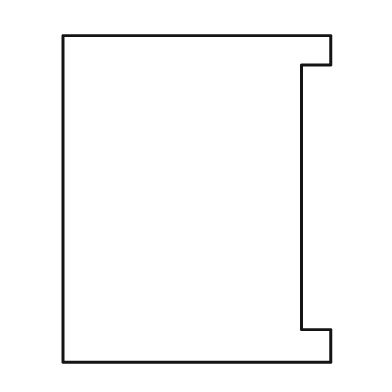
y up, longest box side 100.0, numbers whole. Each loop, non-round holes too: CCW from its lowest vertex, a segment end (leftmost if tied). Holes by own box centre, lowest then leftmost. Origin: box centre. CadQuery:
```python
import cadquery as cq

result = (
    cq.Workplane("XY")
    .moveTo(-41.0, -50.0)
    .lineTo(41.0, -50.0)
    .lineTo(41.0, -40.0)
    .lineTo(32.0, -40.0)
    .lineTo(32.0, 41.0)
    .lineTo(41.0, 41.0)
    .lineTo(41.0, 50.0)
    .lineTo(-41.0, 50.0)
    .close()
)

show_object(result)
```